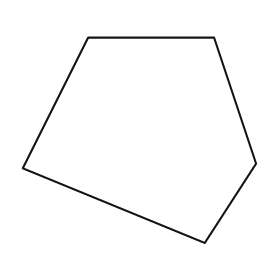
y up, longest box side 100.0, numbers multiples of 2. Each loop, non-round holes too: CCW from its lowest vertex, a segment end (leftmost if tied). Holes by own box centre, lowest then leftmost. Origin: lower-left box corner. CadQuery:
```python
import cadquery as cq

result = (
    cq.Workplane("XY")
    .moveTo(78.0, 0.0)
    .lineTo(100.0, 34.0)
    .lineTo(82.0, 88.0)
    .lineTo(28.0, 88.0)
    .lineTo(0.0, 32.0)
    .close()
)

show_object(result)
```